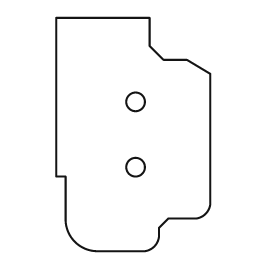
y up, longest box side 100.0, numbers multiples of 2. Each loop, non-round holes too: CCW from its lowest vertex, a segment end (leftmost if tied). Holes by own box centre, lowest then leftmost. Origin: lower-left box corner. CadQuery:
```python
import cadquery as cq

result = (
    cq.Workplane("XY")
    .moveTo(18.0, 0.0)
    .lineTo(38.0, 0.0)
    .threePointArc((42.0, 2.0), (44.0, 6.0))
    .lineTo(44.0, 10.0)
    .lineTo(48.0, 14.0)
    .lineTo(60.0, 14.0)
    .threePointArc((64.0, 16.0), (66.0, 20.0))
    .lineTo(66.0, 76.0)
    .lineTo(56.0, 82.0)
    .lineTo(46.0, 82.0)
    .lineTo(40.0, 88.0)
    .lineTo(40.0, 100.0)
    .lineTo(0.0, 100.0)
    .lineTo(0.0, 32.0)
    .lineTo(4.0, 32.0)
    .lineTo(4.0, 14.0)
    .threePointArc((8.0, 4.0), (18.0, 0.0))
    .close()
    .moveTo(34.0, 36.0)
    .circle(4.0)
    .moveTo(34.0, 64.0)
    .circle(4.0)
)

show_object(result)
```